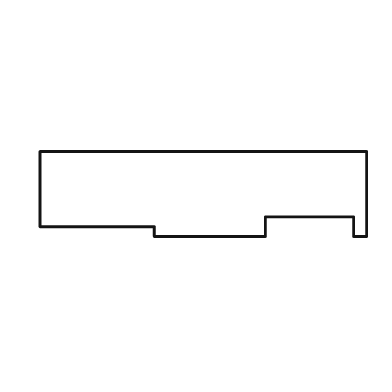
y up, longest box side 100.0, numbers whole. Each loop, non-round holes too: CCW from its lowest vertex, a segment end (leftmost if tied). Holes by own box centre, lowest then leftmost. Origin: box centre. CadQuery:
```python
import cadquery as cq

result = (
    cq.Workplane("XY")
    .moveTo(-15.0, -13.0)
    .lineTo(19.0, -13.0)
    .lineTo(19.0, -7.0)
    .lineTo(46.0, -7.0)
    .lineTo(46.0, -13.0)
    .lineTo(50.0, -13.0)
    .lineTo(50.0, 13.0)
    .lineTo(-50.0, 13.0)
    .lineTo(-50.0, -10.0)
    .lineTo(-15.0, -10.0)
    .close()
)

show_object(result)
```